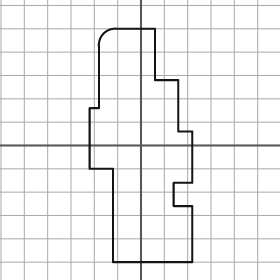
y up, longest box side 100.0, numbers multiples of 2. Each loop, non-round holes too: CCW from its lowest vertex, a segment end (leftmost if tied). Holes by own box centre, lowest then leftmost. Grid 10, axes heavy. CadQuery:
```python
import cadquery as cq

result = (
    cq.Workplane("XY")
    .moveTo(-12.0, -50.0)
    .lineTo(22.0, -50.0)
    .lineTo(22.0, -26.0)
    .lineTo(14.0, -26.0)
    .lineTo(14.0, -16.0)
    .lineTo(22.0, -16.0)
    .lineTo(22.0, 6.0)
    .lineTo(16.0, 6.0)
    .lineTo(16.0, 28.0)
    .lineTo(6.0, 28.0)
    .lineTo(6.0, 50.0)
    .lineTo(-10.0, 50.0)
    .threePointArc((-16.0, 48.0), (-18.0, 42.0))
    .lineTo(-18.0, 16.0)
    .lineTo(-22.0, 16.0)
    .lineTo(-22.0, -10.0)
    .lineTo(-12.0, -10.0)
    .close()
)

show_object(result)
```